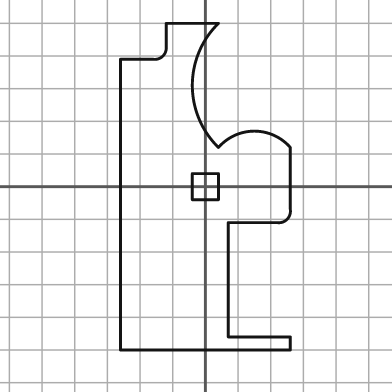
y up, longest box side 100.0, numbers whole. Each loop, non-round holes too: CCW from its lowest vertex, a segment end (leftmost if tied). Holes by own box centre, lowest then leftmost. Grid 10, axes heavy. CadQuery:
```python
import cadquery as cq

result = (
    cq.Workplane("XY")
    .moveTo(-26.0, -50.0)
    .lineTo(26.0, -50.0)
    .lineTo(26.0, -46.0)
    .lineTo(7.0, -46.0)
    .lineTo(7.0, -11.0)
    .lineTo(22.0, -11.0)
    .threePointArc((25.0, -10.0), (26.0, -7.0))
    .lineTo(26.0, 12.0)
    .threePointArc((15.0, 17.0), (4.0, 12.0))
    .threePointArc((-4.0, 31.0), (4.0, 50.0))
    .lineTo(-12.0, 50.0)
    .lineTo(-12.0, 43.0)
    .threePointArc((-13.0, 40.0), (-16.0, 39.0))
    .lineTo(-26.0, 39.0)
    .close()
    .moveTo(-4.0, -4.0)
    .lineTo(4.0, -4.0)
    .lineTo(4.0, 4.0)
    .lineTo(-4.0, 4.0)
    .close()
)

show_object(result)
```